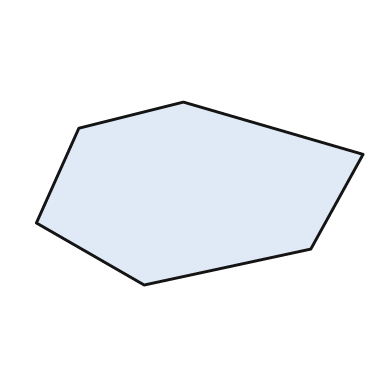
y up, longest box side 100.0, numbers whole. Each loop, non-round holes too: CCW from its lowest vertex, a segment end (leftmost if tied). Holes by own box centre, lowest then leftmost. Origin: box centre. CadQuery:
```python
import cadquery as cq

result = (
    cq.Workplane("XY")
    .moveTo(-17.0, -28.0)
    .lineTo(34.0, -17.0)
    .lineTo(50.0, 12.0)
    .lineTo(-5.0, 28.0)
    .lineTo(-37.0, 20.0)
    .lineTo(-50.0, -9.0)
    .close()
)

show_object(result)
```